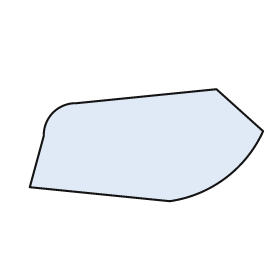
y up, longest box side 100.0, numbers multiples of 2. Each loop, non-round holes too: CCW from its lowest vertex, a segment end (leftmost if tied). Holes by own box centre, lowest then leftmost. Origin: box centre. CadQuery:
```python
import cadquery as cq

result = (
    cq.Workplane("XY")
    .moveTo(10.0, -24.0)
    .threePointArc((34.0, -14.0), (50.0, 6.0))
    .lineTo(30.0, 24.0)
    .lineTo(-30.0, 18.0)
    .threePointArc((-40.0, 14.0), (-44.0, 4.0))
    .lineTo(-50.0, -18.0)
    .close()
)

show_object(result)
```